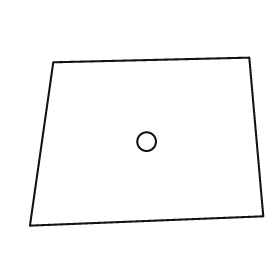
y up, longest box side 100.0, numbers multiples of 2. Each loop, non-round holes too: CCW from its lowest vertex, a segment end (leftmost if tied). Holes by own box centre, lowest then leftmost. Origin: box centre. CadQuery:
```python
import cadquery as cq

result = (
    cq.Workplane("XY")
    .moveTo(-50.0, -36.0)
    .lineTo(50.0, -32.0)
    .lineTo(44.0, 36.0)
    .lineTo(-40.0, 34.0)
    .close()
    .moveTo(0.0, 0.0)
    .circle(4.0)
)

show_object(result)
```